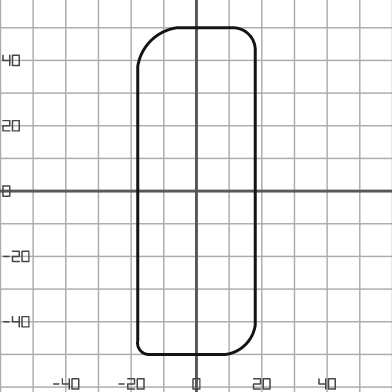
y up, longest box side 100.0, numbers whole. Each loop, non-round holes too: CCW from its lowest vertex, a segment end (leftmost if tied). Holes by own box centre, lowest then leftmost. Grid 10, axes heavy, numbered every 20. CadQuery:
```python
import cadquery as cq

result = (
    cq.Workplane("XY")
    .moveTo(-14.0, -50.0)
    .lineTo(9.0, -50.0)
    .threePointArc((15.0, -47.0), (18.0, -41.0))
    .lineTo(18.0, 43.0)
    .threePointArc((16.0, 48.0), (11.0, 50.0))
    .lineTo(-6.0, 50.0)
    .threePointArc((-14.0, 46.0), (-18.0, 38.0))
    .lineTo(-18.0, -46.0)
    .threePointArc((-17.0, -49.0), (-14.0, -50.0))
    .close()
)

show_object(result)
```